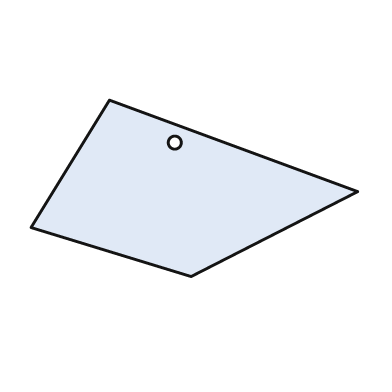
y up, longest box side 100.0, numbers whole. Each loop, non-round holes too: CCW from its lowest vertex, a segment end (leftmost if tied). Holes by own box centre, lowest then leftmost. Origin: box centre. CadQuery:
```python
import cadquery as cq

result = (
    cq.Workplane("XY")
    .moveTo(-1.0, -27.0)
    .lineTo(50.0, -1.0)
    .lineTo(-26.0, 27.0)
    .lineTo(-50.0, -12.0)
    .close()
    .moveTo(-6.0, 14.0)
    .circle(2.0)
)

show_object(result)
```